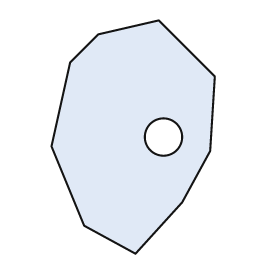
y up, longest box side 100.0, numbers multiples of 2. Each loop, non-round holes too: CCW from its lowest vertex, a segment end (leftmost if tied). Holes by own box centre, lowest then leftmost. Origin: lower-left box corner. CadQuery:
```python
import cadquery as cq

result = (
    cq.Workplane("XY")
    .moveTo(36.0, 0.0)
    .lineTo(56.0, 22.0)
    .lineTo(68.0, 44.0)
    .lineTo(70.0, 76.0)
    .lineTo(46.0, 100.0)
    .lineTo(20.0, 94.0)
    .lineTo(8.0, 82.0)
    .lineTo(0.0, 46.0)
    .lineTo(14.0, 12.0)
    .close()
    .moveTo(48.0, 50.0)
    .circle(8.0)
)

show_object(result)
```